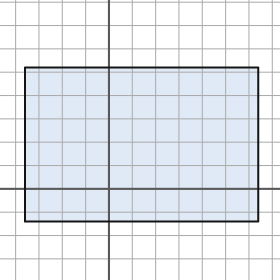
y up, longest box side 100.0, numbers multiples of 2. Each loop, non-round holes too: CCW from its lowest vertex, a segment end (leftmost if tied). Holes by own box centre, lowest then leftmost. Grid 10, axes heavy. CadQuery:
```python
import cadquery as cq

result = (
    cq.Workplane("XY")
    .moveTo(-36.0, -14.0)
    .lineTo(64.0, -14.0)
    .lineTo(64.0, 52.0)
    .lineTo(-36.0, 52.0)
    .close()
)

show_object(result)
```